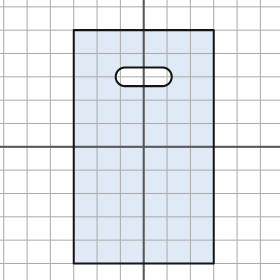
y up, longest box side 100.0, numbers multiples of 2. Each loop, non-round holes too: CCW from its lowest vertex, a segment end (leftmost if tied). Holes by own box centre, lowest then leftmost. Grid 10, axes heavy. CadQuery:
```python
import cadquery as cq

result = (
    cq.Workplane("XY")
    .moveTo(-30.0, -50.0)
    .lineTo(30.0, -50.0)
    .lineTo(30.0, 50.0)
    .lineTo(-30.0, 50.0)
    .close()
    .moveTo(-8.0, 26.0)
    .lineTo(8.0, 26.0)
    .threePointArc((12.0, 30.0), (8.0, 34.0))
    .lineTo(-8.0, 34.0)
    .threePointArc((-12.0, 30.0), (-8.0, 26.0))
    .close()
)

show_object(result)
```